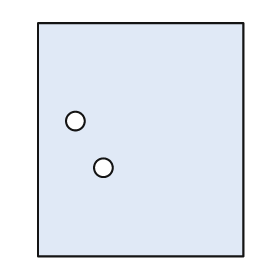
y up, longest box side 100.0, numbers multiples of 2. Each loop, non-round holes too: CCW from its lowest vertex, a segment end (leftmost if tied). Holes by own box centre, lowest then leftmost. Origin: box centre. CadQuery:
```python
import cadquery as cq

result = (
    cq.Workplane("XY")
    .moveTo(-44.0, -50.0)
    .lineTo(44.0, -50.0)
    .lineTo(44.0, 50.0)
    .lineTo(-44.0, 50.0)
    .close()
    .moveTo(-16.0, -12.0)
    .circle(4.0)
    .moveTo(-28.0, 8.0)
    .circle(4.0)
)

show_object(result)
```